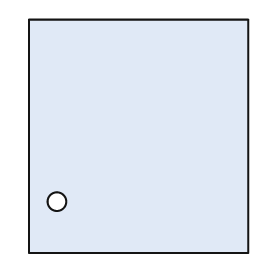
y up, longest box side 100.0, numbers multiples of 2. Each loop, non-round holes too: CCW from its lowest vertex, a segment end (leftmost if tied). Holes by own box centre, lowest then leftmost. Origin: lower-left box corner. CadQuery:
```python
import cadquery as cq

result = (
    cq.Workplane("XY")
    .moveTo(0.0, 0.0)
    .lineTo(94.0, 0.0)
    .lineTo(94.0, 100.0)
    .lineTo(0.0, 100.0)
    .close()
    .moveTo(12.0, 22.0)
    .circle(4.0)
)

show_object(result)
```